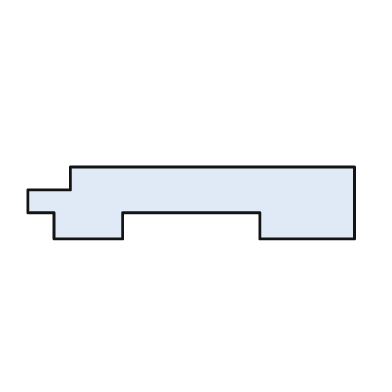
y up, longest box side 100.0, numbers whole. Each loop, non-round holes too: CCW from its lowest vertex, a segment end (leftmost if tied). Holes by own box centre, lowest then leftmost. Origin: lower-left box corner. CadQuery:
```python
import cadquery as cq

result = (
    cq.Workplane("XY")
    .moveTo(8.0, 0.0)
    .lineTo(29.0, 0.0)
    .lineTo(29.0, 8.0)
    .lineTo(71.0, 8.0)
    .lineTo(71.0, 0.0)
    .lineTo(100.0, 0.0)
    .lineTo(100.0, 22.0)
    .lineTo(13.0, 22.0)
    .lineTo(13.0, 15.0)
    .lineTo(0.0, 15.0)
    .lineTo(0.0, 8.0)
    .lineTo(8.0, 8.0)
    .close()
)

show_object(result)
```